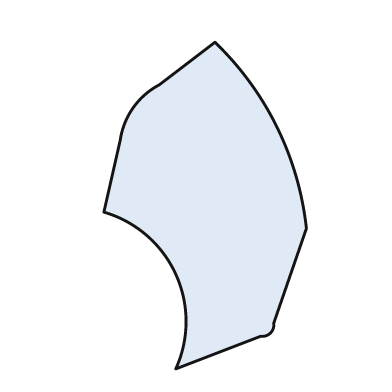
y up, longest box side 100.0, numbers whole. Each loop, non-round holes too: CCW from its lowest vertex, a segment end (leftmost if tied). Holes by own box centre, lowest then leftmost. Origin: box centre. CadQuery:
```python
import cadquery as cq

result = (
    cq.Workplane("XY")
    .moveTo(-9.0, -50.0)
    .lineTo(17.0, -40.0)
    .threePointArc((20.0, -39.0), (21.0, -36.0))
    .lineTo(31.0, -7.0)
    .threePointArc((22.0, 24.0), (3.0, 50.0))
    .lineTo(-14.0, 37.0)
    .threePointArc((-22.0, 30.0), (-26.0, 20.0))
    .lineTo(-31.0, -2.0)
    .threePointArc((-9.0, -21.0), (-9.0, -50.0))
    .close()
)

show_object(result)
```